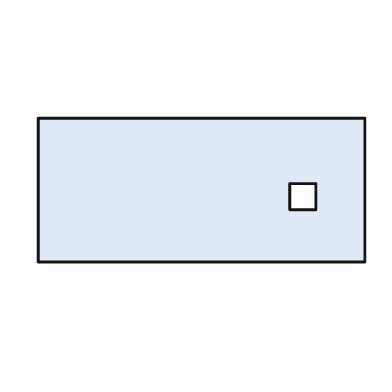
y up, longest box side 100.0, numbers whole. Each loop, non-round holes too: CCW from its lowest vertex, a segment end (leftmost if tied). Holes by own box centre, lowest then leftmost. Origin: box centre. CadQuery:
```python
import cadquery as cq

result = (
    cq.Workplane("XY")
    .moveTo(-50.0, -22.0)
    .lineTo(50.0, -22.0)
    .lineTo(50.0, 22.0)
    .lineTo(-50.0, 22.0)
    .close()
    .moveTo(27.0, -6.0)
    .lineTo(35.0, -6.0)
    .lineTo(35.0, 2.0)
    .lineTo(27.0, 2.0)
    .close()
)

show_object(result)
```